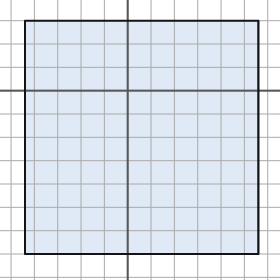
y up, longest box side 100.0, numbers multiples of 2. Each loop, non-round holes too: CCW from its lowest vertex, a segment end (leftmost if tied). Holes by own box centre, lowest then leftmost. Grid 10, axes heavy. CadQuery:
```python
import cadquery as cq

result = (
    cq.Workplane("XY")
    .moveTo(-44.0, -70.0)
    .lineTo(56.0, -70.0)
    .lineTo(56.0, 30.0)
    .lineTo(-44.0, 30.0)
    .close()
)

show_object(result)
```